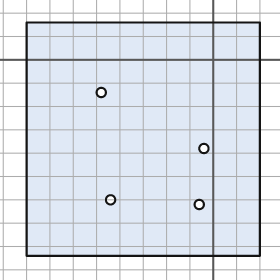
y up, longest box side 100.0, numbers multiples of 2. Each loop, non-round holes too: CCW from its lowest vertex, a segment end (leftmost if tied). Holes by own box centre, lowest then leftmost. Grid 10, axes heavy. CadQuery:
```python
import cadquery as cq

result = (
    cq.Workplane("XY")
    .moveTo(-80.0, -84.0)
    .lineTo(20.0, -84.0)
    .lineTo(20.0, 16.0)
    .lineTo(-80.0, 16.0)
    .close()
    .moveTo(-6.0, -62.0)
    .circle(2.0)
    .moveTo(-44.0, -60.0)
    .circle(2.0)
    .moveTo(-4.0, -38.0)
    .circle(2.0)
    .moveTo(-48.0, -14.0)
    .circle(2.0)
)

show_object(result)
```